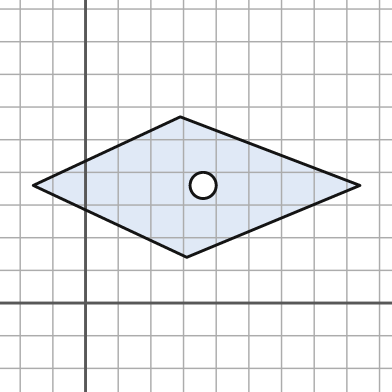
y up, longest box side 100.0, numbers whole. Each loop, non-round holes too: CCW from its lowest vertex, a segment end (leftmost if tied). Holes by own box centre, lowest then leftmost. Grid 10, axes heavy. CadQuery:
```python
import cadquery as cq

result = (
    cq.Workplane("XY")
    .moveTo(31.0, 14.0)
    .lineTo(84.0, 36.0)
    .lineTo(29.0, 57.0)
    .lineTo(-16.0, 36.0)
    .close()
    .moveTo(36.0, 36.0)
    .circle(4.0)
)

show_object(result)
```